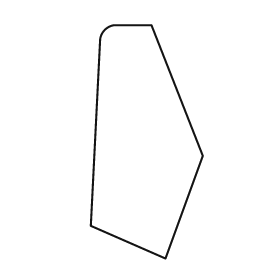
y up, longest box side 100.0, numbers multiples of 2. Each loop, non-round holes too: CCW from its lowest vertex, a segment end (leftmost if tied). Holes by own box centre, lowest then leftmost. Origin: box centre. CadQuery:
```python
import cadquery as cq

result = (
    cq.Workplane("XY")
    .moveTo(8.0, -50.0)
    .lineTo(24.0, -6.0)
    .lineTo(2.0, 50.0)
    .lineTo(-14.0, 50.0)
    .threePointArc((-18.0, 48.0), (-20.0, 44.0))
    .lineTo(-24.0, -36.0)
    .close()
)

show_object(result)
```